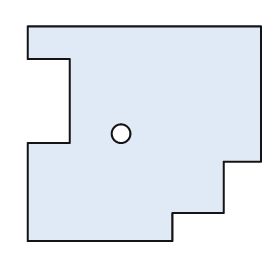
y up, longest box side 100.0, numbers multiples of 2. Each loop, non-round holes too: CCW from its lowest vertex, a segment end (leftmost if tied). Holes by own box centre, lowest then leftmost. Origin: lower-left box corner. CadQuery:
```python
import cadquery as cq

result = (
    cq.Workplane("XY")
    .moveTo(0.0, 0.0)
    .lineTo(62.0, 0.0)
    .lineTo(62.0, 12.0)
    .lineTo(84.0, 12.0)
    .lineTo(84.0, 34.0)
    .lineTo(100.0, 34.0)
    .lineTo(100.0, 92.0)
    .lineTo(0.0, 92.0)
    .lineTo(0.0, 78.0)
    .lineTo(18.0, 78.0)
    .lineTo(18.0, 42.0)
    .lineTo(0.0, 42.0)
    .close()
    .moveTo(40.0, 46.0)
    .circle(4.0)
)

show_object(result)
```